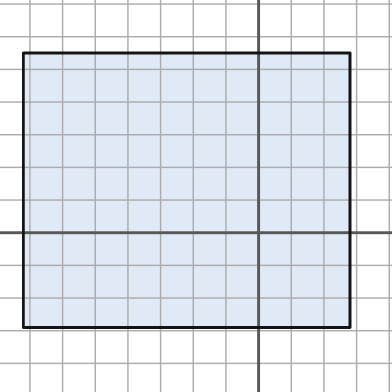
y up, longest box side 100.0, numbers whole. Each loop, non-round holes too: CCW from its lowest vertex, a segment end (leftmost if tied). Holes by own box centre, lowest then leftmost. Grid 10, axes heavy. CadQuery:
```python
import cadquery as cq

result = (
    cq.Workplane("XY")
    .moveTo(-72.0, -29.0)
    .lineTo(28.0, -29.0)
    .lineTo(28.0, 55.0)
    .lineTo(-72.0, 55.0)
    .close()
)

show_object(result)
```